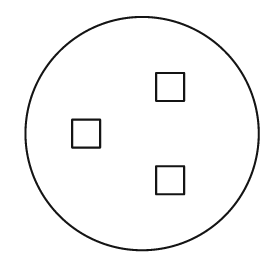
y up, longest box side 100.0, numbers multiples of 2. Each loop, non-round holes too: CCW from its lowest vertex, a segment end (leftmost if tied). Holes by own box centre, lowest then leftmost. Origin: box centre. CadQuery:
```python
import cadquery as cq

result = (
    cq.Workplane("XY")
    .moveTo(0.0, 0.0)
    .circle(50.0)
    .moveTo(6.0, -26.0)
    .lineTo(18.0, -26.0)
    .lineTo(18.0, -14.0)
    .lineTo(6.0, -14.0)
    .close()
    .moveTo(-30.0, -6.0)
    .lineTo(-18.0, -6.0)
    .lineTo(-18.0, 6.0)
    .lineTo(-30.0, 6.0)
    .close()
    .moveTo(6.0, 14.0)
    .lineTo(18.0, 14.0)
    .lineTo(18.0, 26.0)
    .lineTo(6.0, 26.0)
    .close()
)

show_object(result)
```